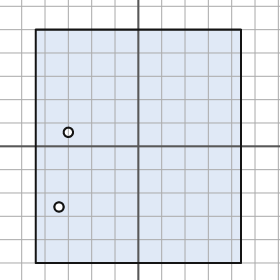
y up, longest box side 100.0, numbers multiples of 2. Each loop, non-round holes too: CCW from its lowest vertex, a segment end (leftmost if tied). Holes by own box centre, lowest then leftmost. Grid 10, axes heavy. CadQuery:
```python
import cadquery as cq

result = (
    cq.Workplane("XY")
    .moveTo(-44.0, -50.0)
    .lineTo(44.0, -50.0)
    .lineTo(44.0, 50.0)
    .lineTo(-44.0, 50.0)
    .close()
    .moveTo(-34.0, -26.0)
    .circle(2.0)
    .moveTo(-30.0, 6.0)
    .circle(2.0)
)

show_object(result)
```